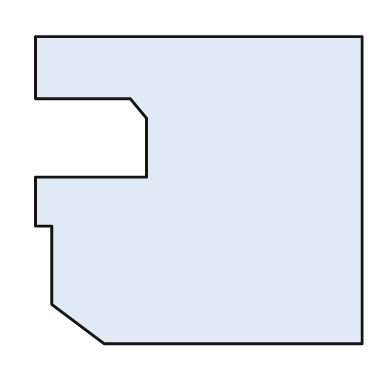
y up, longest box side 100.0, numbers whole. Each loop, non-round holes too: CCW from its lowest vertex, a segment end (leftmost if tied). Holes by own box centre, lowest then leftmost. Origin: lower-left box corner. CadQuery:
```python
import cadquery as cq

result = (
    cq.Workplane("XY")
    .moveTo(21.0, 0.0)
    .lineTo(100.0, 0.0)
    .lineTo(100.0, 94.0)
    .lineTo(0.0, 94.0)
    .lineTo(0.0, 75.0)
    .lineTo(29.0, 75.0)
    .lineTo(34.0, 69.0)
    .lineTo(34.0, 51.0)
    .lineTo(0.0, 51.0)
    .lineTo(0.0, 36.0)
    .lineTo(5.0, 36.0)
    .lineTo(5.0, 12.0)
    .close()
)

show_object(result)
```